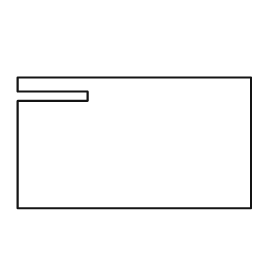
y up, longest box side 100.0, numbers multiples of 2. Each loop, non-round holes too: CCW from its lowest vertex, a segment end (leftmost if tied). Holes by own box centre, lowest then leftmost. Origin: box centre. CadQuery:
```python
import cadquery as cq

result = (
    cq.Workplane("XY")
    .moveTo(-50.0, -28.0)
    .lineTo(50.0, -28.0)
    .lineTo(50.0, 28.0)
    .lineTo(-50.0, 28.0)
    .lineTo(-50.0, 22.0)
    .lineTo(-20.0, 22.0)
    .lineTo(-20.0, 18.0)
    .lineTo(-50.0, 18.0)
    .close()
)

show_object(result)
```